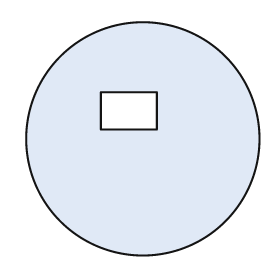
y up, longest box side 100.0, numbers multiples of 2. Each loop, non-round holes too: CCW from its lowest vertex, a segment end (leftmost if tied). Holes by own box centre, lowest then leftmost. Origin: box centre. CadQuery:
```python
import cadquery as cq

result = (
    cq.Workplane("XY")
    .moveTo(0.0, 0.0)
    .circle(50.0)
    .moveTo(-18.0, 4.0)
    .lineTo(6.0, 4.0)
    .lineTo(6.0, 20.0)
    .lineTo(-18.0, 20.0)
    .close()
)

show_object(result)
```